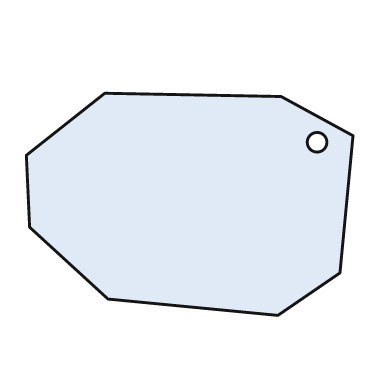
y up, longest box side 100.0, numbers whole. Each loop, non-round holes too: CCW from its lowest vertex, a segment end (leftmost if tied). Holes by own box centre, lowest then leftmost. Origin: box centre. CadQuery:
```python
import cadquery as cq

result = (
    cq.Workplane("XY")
    .moveTo(27.0, -34.0)
    .lineTo(46.0, -21.0)
    .lineTo(50.0, 21.0)
    .lineTo(28.0, 33.0)
    .lineTo(-26.0, 34.0)
    .lineTo(-50.0, 15.0)
    .lineTo(-49.0, -7.0)
    .lineTo(-25.0, -29.0)
    .close()
    .moveTo(39.0, 19.0)
    .circle(3.0)
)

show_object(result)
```